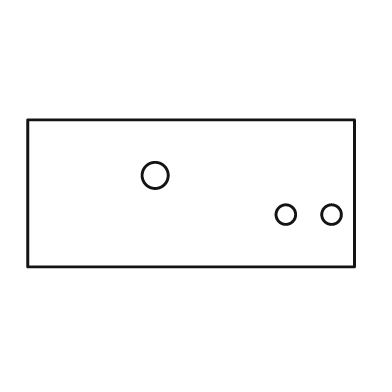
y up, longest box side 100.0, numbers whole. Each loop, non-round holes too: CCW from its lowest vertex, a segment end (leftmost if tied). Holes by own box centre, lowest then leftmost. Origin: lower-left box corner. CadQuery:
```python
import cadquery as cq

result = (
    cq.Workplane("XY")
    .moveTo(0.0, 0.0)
    .lineTo(100.0, 0.0)
    .lineTo(100.0, 45.0)
    .lineTo(0.0, 45.0)
    .close()
    .moveTo(79.0, 16.0)
    .circle(3.0)
    .moveTo(93.0, 16.0)
    .circle(3.0)
    .moveTo(39.0, 28.0)
    .circle(4.0)
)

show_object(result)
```